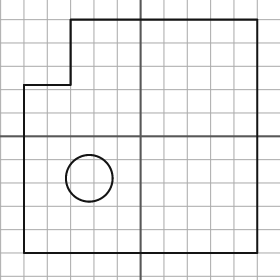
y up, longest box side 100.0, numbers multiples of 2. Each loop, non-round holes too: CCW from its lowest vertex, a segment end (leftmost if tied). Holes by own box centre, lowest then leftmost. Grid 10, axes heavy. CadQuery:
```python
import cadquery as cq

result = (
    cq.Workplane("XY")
    .moveTo(-50.0, -50.0)
    .lineTo(50.0, -50.0)
    .lineTo(50.0, 50.0)
    .lineTo(-30.0, 50.0)
    .lineTo(-30.0, 22.0)
    .lineTo(-50.0, 22.0)
    .close()
    .moveTo(-22.0, -18.0)
    .circle(10.0)
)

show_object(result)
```